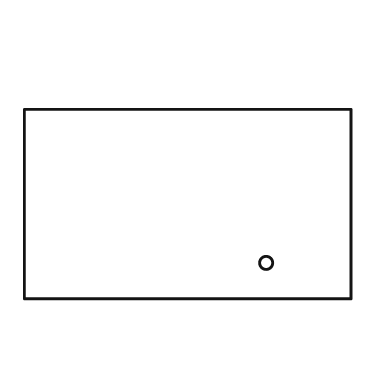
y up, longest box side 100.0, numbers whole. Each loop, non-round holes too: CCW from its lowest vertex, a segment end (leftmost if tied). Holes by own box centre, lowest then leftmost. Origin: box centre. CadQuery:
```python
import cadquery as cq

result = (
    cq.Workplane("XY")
    .moveTo(-50.0, -29.0)
    .lineTo(50.0, -29.0)
    .lineTo(50.0, 29.0)
    .lineTo(-50.0, 29.0)
    .close()
    .moveTo(24.0, -18.0)
    .circle(2.0)
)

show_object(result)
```